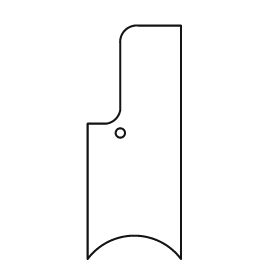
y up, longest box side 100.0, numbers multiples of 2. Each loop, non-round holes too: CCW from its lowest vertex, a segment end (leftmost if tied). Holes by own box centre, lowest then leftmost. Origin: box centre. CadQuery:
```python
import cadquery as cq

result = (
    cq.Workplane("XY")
    .moveTo(-20.0, -50.0)
    .threePointArc((0.0, -40.0), (20.0, -50.0))
    .lineTo(20.0, 50.0)
    .lineTo(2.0, 50.0)
    .threePointArc((-4.0, 48.0), (-6.0, 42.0))
    .lineTo(-6.0, 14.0)
    .threePointArc((-8.0, 10.0), (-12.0, 8.0))
    .lineTo(-20.0, 8.0)
    .close()
    .moveTo(-6.0, 4.0)
    .circle(2.0)
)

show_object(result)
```